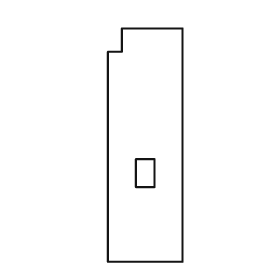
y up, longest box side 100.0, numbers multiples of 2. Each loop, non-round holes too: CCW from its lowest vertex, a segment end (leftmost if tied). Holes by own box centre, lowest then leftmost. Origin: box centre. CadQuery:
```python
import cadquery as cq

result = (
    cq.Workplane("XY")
    .moveTo(-16.0, -50.0)
    .lineTo(16.0, -50.0)
    .lineTo(16.0, 50.0)
    .lineTo(-10.0, 50.0)
    .lineTo(-10.0, 40.0)
    .lineTo(-16.0, 40.0)
    .close()
    .moveTo(-4.0, -18.0)
    .lineTo(4.0, -18.0)
    .lineTo(4.0, -6.0)
    .lineTo(-4.0, -6.0)
    .close()
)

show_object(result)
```